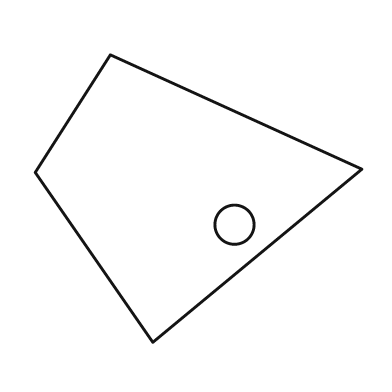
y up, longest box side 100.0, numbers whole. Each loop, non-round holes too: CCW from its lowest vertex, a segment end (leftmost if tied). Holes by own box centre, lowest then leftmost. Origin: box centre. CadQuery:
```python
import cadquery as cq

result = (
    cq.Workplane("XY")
    .moveTo(-14.0, -44.0)
    .lineTo(50.0, 9.0)
    .lineTo(-27.0, 44.0)
    .lineTo(-50.0, 8.0)
    .close()
    .moveTo(11.0, -8.0)
    .circle(6.0)
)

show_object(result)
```